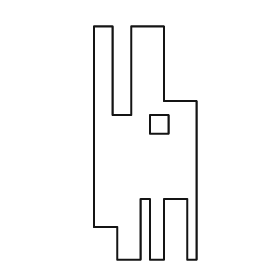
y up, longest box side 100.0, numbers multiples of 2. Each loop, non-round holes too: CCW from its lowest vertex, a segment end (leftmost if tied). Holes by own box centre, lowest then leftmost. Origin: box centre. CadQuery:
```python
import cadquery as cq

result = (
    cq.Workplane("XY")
    .moveTo(-12.0, -50.0)
    .lineTo(-2.0, -50.0)
    .lineTo(-2.0, -24.0)
    .lineTo(2.0, -24.0)
    .lineTo(2.0, -50.0)
    .lineTo(8.0, -50.0)
    .lineTo(8.0, -24.0)
    .lineTo(18.0, -24.0)
    .lineTo(18.0, -50.0)
    .lineTo(22.0, -50.0)
    .lineTo(22.0, 18.0)
    .lineTo(8.0, 18.0)
    .lineTo(8.0, 50.0)
    .lineTo(-6.0, 50.0)
    .lineTo(-6.0, 12.0)
    .lineTo(-14.0, 12.0)
    .lineTo(-14.0, 50.0)
    .lineTo(-22.0, 50.0)
    .lineTo(-22.0, -36.0)
    .lineTo(-12.0, -36.0)
    .close()
    .moveTo(2.0, 4.0)
    .lineTo(10.0, 4.0)
    .lineTo(10.0, 12.0)
    .lineTo(2.0, 12.0)
    .close()
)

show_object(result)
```